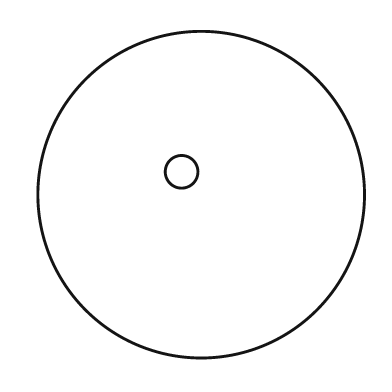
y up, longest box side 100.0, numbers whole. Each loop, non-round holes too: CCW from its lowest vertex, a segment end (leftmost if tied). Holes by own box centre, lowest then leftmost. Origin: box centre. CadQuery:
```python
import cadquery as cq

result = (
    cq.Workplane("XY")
    .moveTo(0.0, 0.0)
    .circle(50.0)
    .moveTo(-6.0, 7.0)
    .circle(5.0)
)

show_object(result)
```